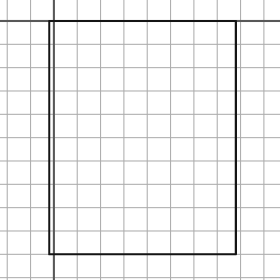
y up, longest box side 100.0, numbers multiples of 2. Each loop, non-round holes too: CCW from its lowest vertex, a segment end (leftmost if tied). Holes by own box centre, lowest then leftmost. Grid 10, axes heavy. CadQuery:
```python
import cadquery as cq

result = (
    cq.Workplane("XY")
    .moveTo(-2.0, -100.0)
    .lineTo(78.0, -100.0)
    .lineTo(78.0, 0.0)
    .lineTo(-2.0, 0.0)
    .close()
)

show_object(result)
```